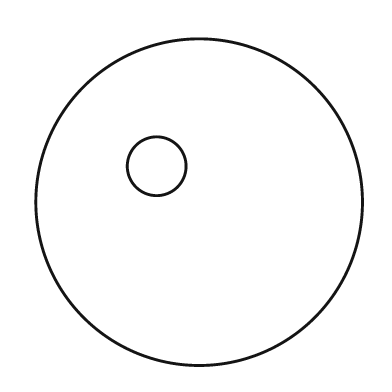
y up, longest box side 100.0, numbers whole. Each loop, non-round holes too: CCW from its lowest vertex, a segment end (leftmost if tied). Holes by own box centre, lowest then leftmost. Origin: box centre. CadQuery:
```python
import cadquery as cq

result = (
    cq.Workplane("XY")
    .moveTo(0.0, 0.0)
    .circle(50.0)
    .moveTo(-13.0, 11.0)
    .circle(9.0)
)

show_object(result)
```